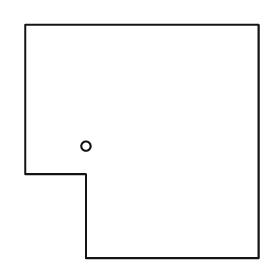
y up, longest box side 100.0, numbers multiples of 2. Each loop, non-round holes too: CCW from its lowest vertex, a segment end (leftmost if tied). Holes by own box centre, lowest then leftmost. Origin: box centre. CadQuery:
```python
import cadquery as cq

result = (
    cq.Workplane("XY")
    .moveTo(-24.0, -50.0)
    .lineTo(50.0, -50.0)
    .lineTo(50.0, 50.0)
    .lineTo(-50.0, 50.0)
    .lineTo(-50.0, -14.0)
    .lineTo(-24.0, -14.0)
    .close()
    .moveTo(-24.0, -2.0)
    .circle(2.0)
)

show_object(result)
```